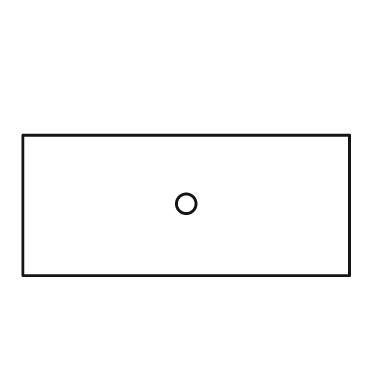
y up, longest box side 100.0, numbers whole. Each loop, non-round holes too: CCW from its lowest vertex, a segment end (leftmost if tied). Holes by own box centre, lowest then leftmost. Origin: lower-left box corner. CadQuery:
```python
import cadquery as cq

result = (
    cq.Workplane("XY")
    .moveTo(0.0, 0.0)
    .lineTo(100.0, 0.0)
    .lineTo(100.0, 43.0)
    .lineTo(0.0, 43.0)
    .close()
    .moveTo(50.0, 22.0)
    .circle(3.0)
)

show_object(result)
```